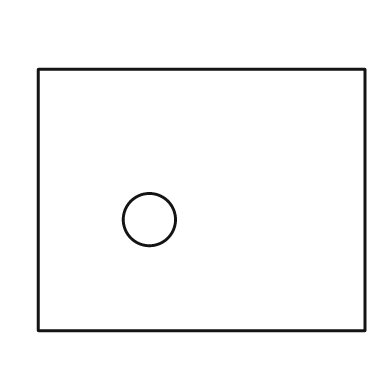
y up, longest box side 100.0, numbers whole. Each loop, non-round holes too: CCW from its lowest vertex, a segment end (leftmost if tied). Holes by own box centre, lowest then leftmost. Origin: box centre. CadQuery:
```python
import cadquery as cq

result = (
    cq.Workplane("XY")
    .moveTo(-50.0, -40.0)
    .lineTo(50.0, -40.0)
    .lineTo(50.0, 40.0)
    .lineTo(-50.0, 40.0)
    .close()
    .moveTo(-16.0, -6.0)
    .circle(8.0)
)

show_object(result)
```